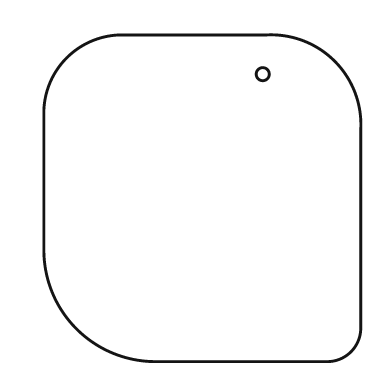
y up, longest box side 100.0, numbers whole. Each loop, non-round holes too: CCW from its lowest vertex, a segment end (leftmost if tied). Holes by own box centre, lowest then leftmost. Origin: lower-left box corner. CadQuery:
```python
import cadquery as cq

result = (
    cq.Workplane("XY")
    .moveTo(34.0, 0.0)
    .lineTo(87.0, 0.0)
    .threePointArc((94.0, 3.0), (97.0, 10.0))
    .lineTo(97.0, 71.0)
    .threePointArc((89.0, 92.0), (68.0, 100.0))
    .lineTo(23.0, 100.0)
    .threePointArc((7.0, 93.0), (0.0, 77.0))
    .lineTo(0.0, 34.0)
    .threePointArc((10.0, 10.0), (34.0, 0.0))
    .close()
    .moveTo(67.0, 88.0)
    .circle(2.0)
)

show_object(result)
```